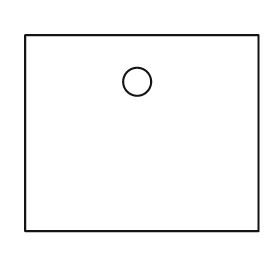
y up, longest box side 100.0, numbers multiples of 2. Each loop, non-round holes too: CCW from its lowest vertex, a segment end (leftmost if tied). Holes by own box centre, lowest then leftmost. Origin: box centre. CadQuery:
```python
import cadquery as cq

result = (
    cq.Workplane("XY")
    .moveTo(-50.0, -42.0)
    .lineTo(50.0, -42.0)
    .lineTo(50.0, 42.0)
    .lineTo(-50.0, 42.0)
    .close()
    .moveTo(-2.0, 22.0)
    .circle(6.0)
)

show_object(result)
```